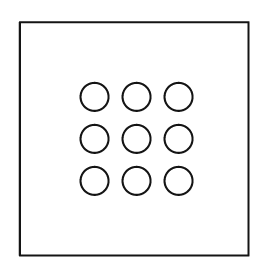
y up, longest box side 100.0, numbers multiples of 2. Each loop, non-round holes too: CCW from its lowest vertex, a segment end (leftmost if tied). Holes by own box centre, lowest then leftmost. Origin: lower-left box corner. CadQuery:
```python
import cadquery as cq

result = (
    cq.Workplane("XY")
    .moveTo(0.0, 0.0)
    .lineTo(98.0, 0.0)
    .lineTo(98.0, 100.0)
    .lineTo(0.0, 100.0)
    .close()
    .moveTo(32.0, 32.0)
    .circle(6.0)
    .moveTo(50.0, 32.0)
    .circle(6.0)
    .moveTo(68.0, 32.0)
    .circle(6.0)
    .moveTo(32.0, 50.0)
    .circle(6.0)
    .moveTo(50.0, 50.0)
    .circle(6.0)
    .moveTo(68.0, 50.0)
    .circle(6.0)
    .moveTo(32.0, 68.0)
    .circle(6.0)
    .moveTo(50.0, 68.0)
    .circle(6.0)
    .moveTo(68.0, 68.0)
    .circle(6.0)
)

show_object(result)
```